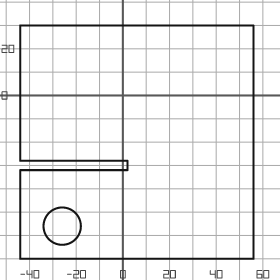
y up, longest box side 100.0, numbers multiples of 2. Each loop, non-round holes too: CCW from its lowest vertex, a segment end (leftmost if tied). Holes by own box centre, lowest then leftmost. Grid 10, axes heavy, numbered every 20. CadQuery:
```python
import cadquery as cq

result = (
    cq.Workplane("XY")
    .moveTo(-44.0, -70.0)
    .lineTo(56.0, -70.0)
    .lineTo(56.0, 30.0)
    .lineTo(-44.0, 30.0)
    .lineTo(-44.0, -28.0)
    .lineTo(2.0, -28.0)
    .lineTo(2.0, -32.0)
    .lineTo(-44.0, -32.0)
    .close()
    .moveTo(-26.0, -56.0)
    .circle(8.0)
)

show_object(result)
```